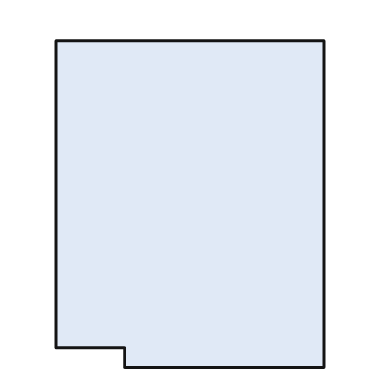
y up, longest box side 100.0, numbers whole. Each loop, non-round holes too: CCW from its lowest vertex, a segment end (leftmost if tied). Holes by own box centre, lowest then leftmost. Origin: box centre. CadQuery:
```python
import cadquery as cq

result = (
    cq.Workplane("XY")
    .moveTo(-20.0, -50.0)
    .lineTo(41.0, -50.0)
    .lineTo(41.0, 50.0)
    .lineTo(-41.0, 50.0)
    .lineTo(-41.0, -44.0)
    .lineTo(-20.0, -44.0)
    .close()
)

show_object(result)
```